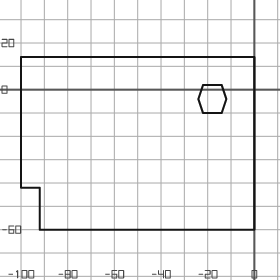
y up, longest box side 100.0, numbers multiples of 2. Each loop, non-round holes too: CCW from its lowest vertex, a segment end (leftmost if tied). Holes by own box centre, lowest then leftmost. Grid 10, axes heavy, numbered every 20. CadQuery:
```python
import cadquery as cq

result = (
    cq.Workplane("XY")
    .moveTo(-92.0, -60.0)
    .lineTo(0.0, -60.0)
    .lineTo(0.0, 14.0)
    .lineTo(-100.0, 14.0)
    .lineTo(-100.0, -42.0)
    .lineTo(-92.0, -42.0)
    .close()
    .moveTo(-22.0, -10.0)
    .lineTo(-14.0, -10.0)
    .lineTo(-12.0, -4.0)
    .lineTo(-14.0, 2.0)
    .lineTo(-22.0, 2.0)
    .lineTo(-24.0, -4.0)
    .close()
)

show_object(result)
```